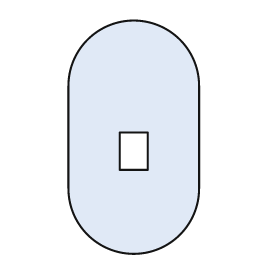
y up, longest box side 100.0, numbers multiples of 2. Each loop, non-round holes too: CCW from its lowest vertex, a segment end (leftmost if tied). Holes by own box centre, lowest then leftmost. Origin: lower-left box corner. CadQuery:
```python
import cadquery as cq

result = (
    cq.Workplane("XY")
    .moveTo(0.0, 28.0)
    .threePointArc((28.0, 0.0), (56.0, 28.0))
    .lineTo(56.0, 72.0)
    .threePointArc((28.0, 100.0), (0.0, 72.0))
    .close()
    .moveTo(22.0, 36.0)
    .lineTo(34.0, 36.0)
    .lineTo(34.0, 52.0)
    .lineTo(22.0, 52.0)
    .close()
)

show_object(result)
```